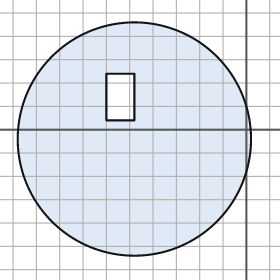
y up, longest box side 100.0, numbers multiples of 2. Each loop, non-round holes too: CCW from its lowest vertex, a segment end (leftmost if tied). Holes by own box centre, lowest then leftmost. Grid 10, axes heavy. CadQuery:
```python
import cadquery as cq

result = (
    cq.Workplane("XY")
    .moveTo(-48.0, -4.0)
    .circle(50.0)
    .moveTo(-60.0, 4.0)
    .lineTo(-48.0, 4.0)
    .lineTo(-48.0, 24.0)
    .lineTo(-60.0, 24.0)
    .close()
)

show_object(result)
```